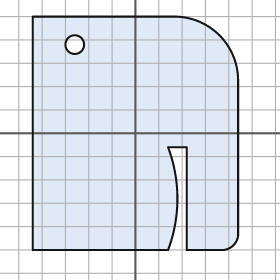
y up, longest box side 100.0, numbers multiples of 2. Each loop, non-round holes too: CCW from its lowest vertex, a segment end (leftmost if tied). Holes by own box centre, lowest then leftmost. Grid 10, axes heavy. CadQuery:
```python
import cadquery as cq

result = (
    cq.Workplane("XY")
    .moveTo(-44.0, -50.0)
    .lineTo(14.0, -50.0)
    .threePointArc((18.0, -28.0), (14.0, -6.0))
    .lineTo(22.0, -6.0)
    .lineTo(22.0, -50.0)
    .lineTo(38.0, -50.0)
    .threePointArc((42.0, -48.0), (44.0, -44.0))
    .lineTo(44.0, 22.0)
    .threePointArc((36.0, 42.0), (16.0, 50.0))
    .lineTo(-44.0, 50.0)
    .close()
    .moveTo(-26.0, 38.0)
    .circle(4.0)
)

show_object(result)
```